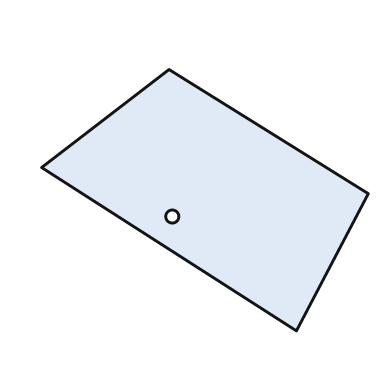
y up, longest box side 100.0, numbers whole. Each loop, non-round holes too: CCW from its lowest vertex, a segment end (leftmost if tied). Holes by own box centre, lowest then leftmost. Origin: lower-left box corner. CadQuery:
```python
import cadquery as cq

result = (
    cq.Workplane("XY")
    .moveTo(78.0, 0.0)
    .lineTo(100.0, 42.0)
    .lineTo(39.0, 80.0)
    .lineTo(0.0, 50.0)
    .close()
    .moveTo(40.0, 35.0)
    .circle(2.0)
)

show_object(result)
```